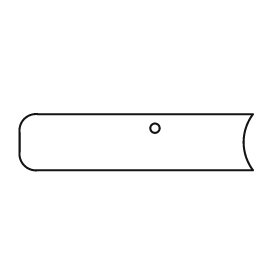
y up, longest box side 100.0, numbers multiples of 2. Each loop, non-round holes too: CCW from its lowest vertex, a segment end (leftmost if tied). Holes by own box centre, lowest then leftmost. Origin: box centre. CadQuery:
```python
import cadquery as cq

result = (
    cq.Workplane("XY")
    .moveTo(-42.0, -12.0)
    .lineTo(50.0, -12.0)
    .threePointArc((46.0, 0.0), (50.0, 12.0))
    .lineTo(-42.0, 12.0)
    .threePointArc((-48.0, 10.0), (-50.0, 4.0))
    .lineTo(-50.0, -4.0)
    .threePointArc((-48.0, -10.0), (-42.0, -12.0))
    .close()
    .moveTo(8.0, 6.0)
    .circle(2.0)
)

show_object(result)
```